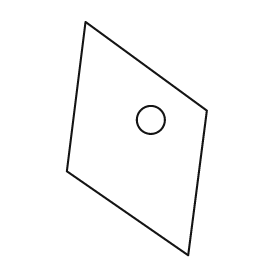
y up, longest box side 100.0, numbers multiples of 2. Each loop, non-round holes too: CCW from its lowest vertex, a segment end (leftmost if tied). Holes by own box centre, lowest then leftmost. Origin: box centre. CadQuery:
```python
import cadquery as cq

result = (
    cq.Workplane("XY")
    .moveTo(22.0, -50.0)
    .lineTo(30.0, 12.0)
    .lineTo(-22.0, 50.0)
    .lineTo(-30.0, -14.0)
    .close()
    .moveTo(6.0, 8.0)
    .circle(6.0)
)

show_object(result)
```